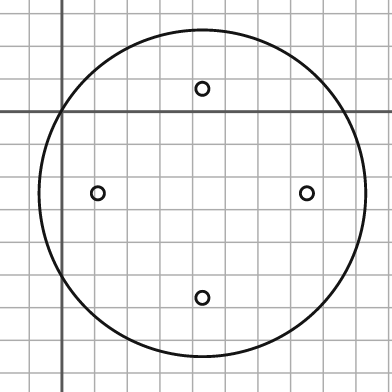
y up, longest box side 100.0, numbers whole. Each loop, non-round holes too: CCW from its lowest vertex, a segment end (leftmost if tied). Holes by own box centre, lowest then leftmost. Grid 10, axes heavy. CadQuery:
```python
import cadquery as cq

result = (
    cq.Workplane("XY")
    .moveTo(43.0, -25.0)
    .circle(50.0)
    .moveTo(43.0, -57.0)
    .circle(2.0)
    .moveTo(11.0, -25.0)
    .circle(2.0)
    .moveTo(75.0, -25.0)
    .circle(2.0)
    .moveTo(43.0, 7.0)
    .circle(2.0)
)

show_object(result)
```